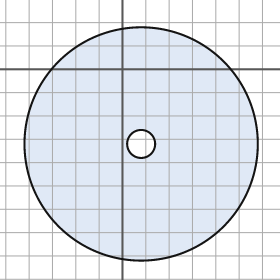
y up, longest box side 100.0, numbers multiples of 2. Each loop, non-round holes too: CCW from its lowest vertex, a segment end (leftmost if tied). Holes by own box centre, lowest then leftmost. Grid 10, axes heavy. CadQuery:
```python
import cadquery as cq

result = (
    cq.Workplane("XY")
    .moveTo(8.0, -32.0)
    .circle(50.0)
    .moveTo(8.0, -32.0)
    .circle(6.0)
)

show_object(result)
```